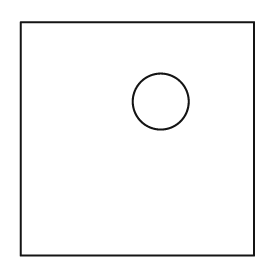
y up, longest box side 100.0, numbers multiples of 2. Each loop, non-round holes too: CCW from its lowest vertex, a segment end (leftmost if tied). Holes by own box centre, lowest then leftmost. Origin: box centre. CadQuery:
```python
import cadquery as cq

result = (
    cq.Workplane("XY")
    .moveTo(-50.0, -50.0)
    .lineTo(50.0, -50.0)
    .lineTo(50.0, 50.0)
    .lineTo(-50.0, 50.0)
    .close()
    .moveTo(10.0, 16.0)
    .circle(12.0)
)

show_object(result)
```